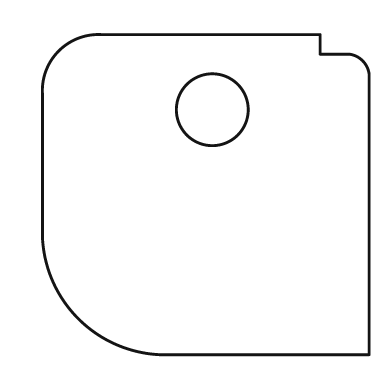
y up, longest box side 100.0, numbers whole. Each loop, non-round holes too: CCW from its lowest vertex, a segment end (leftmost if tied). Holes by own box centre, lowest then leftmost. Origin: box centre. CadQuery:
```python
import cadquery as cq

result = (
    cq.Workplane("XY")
    .moveTo(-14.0, -49.0)
    .lineTo(50.0, -49.0)
    .lineTo(50.0, 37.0)
    .threePointArc((48.0, 41.0), (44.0, 43.0))
    .lineTo(35.0, 43.0)
    .lineTo(35.0, 49.0)
    .lineTo(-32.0, 49.0)
    .threePointArc((-45.0, 44.0), (-50.0, 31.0))
    .lineTo(-50.0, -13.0)
    .threePointArc((-39.0, -38.0), (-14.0, -49.0))
    .close()
    .moveTo(2.0, 26.0)
    .circle(11.0)
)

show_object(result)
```